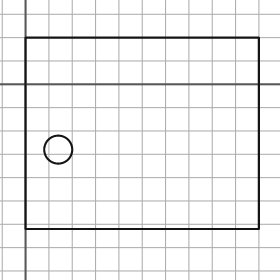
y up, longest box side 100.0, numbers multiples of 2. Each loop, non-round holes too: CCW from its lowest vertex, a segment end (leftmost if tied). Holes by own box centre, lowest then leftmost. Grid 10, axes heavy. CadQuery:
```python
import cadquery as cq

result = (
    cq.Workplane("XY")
    .moveTo(0.0, -62.0)
    .lineTo(100.0, -62.0)
    .lineTo(100.0, 20.0)
    .lineTo(0.0, 20.0)
    .close()
    .moveTo(14.0, -28.0)
    .circle(6.0)
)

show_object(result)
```